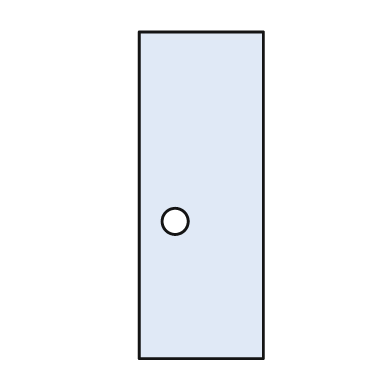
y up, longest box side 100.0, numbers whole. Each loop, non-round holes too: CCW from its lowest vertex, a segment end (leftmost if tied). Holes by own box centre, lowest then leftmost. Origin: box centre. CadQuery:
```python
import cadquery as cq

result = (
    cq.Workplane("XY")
    .moveTo(-19.0, -50.0)
    .lineTo(19.0, -50.0)
    .lineTo(19.0, 50.0)
    .lineTo(-19.0, 50.0)
    .close()
    .moveTo(-8.0, -8.0)
    .circle(4.0)
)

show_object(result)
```